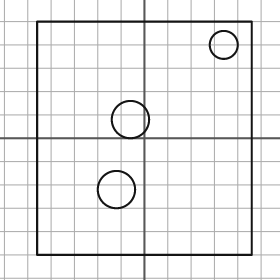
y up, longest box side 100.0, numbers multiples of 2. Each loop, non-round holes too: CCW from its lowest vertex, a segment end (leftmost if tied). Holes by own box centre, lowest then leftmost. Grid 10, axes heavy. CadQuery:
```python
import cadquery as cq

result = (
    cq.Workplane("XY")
    .moveTo(-46.0, -50.0)
    .lineTo(46.0, -50.0)
    .lineTo(46.0, 50.0)
    .lineTo(-46.0, 50.0)
    .close()
    .moveTo(-12.0, -22.0)
    .circle(8.0)
    .moveTo(-6.0, 8.0)
    .circle(8.0)
    .moveTo(34.0, 40.0)
    .circle(6.0)
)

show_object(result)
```